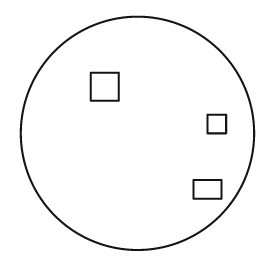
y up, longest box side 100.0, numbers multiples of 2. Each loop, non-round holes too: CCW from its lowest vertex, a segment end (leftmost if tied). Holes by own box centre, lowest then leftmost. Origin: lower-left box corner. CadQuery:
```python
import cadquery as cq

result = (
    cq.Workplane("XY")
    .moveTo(50.0, 50.0)
    .circle(50.0)
    .moveTo(74.0, 22.0)
    .lineTo(86.0, 22.0)
    .lineTo(86.0, 30.0)
    .lineTo(74.0, 30.0)
    .close()
    .moveTo(80.0, 50.0)
    .lineTo(88.0, 50.0)
    .lineTo(88.0, 58.0)
    .lineTo(80.0, 58.0)
    .close()
    .moveTo(30.0, 64.0)
    .lineTo(42.0, 64.0)
    .lineTo(42.0, 76.0)
    .lineTo(30.0, 76.0)
    .close()
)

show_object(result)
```